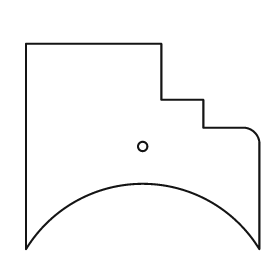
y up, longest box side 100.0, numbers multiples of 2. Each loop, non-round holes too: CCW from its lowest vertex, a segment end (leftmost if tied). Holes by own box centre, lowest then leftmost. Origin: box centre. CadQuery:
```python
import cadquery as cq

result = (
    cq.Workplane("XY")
    .moveTo(-50.0, -44.0)
    .threePointArc((0.0, -16.0), (50.0, -44.0))
    .lineTo(50.0, 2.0)
    .threePointArc((48.0, 6.0), (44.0, 8.0))
    .lineTo(26.0, 8.0)
    .lineTo(26.0, 20.0)
    .lineTo(8.0, 20.0)
    .lineTo(8.0, 44.0)
    .lineTo(-50.0, 44.0)
    .close()
    .moveTo(0.0, 0.0)
    .circle(2.0)
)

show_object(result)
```